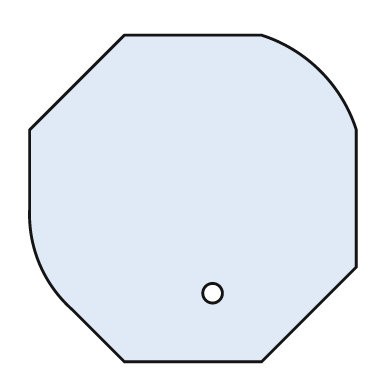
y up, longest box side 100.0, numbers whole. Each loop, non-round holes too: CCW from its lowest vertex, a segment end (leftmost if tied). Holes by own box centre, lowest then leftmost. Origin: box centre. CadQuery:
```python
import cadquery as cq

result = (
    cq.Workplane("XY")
    .moveTo(-21.0, -50.0)
    .lineTo(21.0, -50.0)
    .lineTo(50.0, -21.0)
    .lineTo(50.0, 21.0)
    .threePointArc((39.0, 39.0), (21.0, 50.0))
    .lineTo(-21.0, 50.0)
    .lineTo(-50.0, 21.0)
    .lineTo(-50.0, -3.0)
    .threePointArc((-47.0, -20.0), (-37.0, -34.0))
    .close()
    .moveTo(6.0, -29.0)
    .circle(3.0)
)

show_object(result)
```